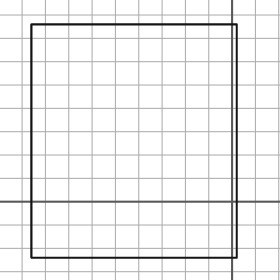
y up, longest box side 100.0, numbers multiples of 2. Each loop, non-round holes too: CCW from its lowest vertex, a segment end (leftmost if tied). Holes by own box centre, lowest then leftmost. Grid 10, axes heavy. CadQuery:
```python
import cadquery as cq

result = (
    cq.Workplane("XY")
    .moveTo(-86.0, -24.0)
    .lineTo(2.0, -24.0)
    .lineTo(2.0, 76.0)
    .lineTo(-86.0, 76.0)
    .close()
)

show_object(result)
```